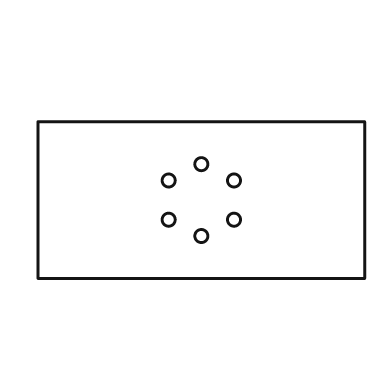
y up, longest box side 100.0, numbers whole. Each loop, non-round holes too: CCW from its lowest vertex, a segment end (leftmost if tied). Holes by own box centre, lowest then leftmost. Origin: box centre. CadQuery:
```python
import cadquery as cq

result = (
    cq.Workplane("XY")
    .moveTo(-50.0, -24.0)
    .lineTo(50.0, -24.0)
    .lineTo(50.0, 24.0)
    .lineTo(-50.0, 24.0)
    .close()
    .moveTo(0.0, -11.0)
    .circle(2.0)
    .moveTo(-10.0, -6.0)
    .circle(2.0)
    .moveTo(10.0, -6.0)
    .circle(2.0)
    .moveTo(-10.0, 6.0)
    .circle(2.0)
    .moveTo(10.0, 6.0)
    .circle(2.0)
    .moveTo(0.0, 11.0)
    .circle(2.0)
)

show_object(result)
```